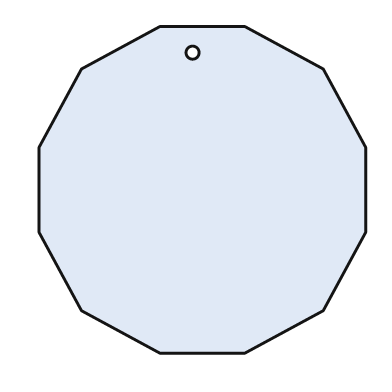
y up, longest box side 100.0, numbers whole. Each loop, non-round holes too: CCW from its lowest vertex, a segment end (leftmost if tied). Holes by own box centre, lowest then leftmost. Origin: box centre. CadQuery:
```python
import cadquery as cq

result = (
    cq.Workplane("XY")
    .moveTo(-13.0, -50.0)
    .lineTo(13.0, -50.0)
    .lineTo(37.0, -37.0)
    .lineTo(50.0, -13.0)
    .lineTo(50.0, 13.0)
    .lineTo(37.0, 37.0)
    .lineTo(13.0, 50.0)
    .lineTo(-13.0, 50.0)
    .lineTo(-37.0, 37.0)
    .lineTo(-50.0, 13.0)
    .lineTo(-50.0, -13.0)
    .lineTo(-37.0, -37.0)
    .close()
    .moveTo(-3.0, 42.0)
    .circle(2.0)
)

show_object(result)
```